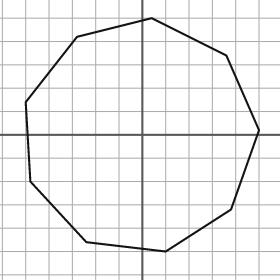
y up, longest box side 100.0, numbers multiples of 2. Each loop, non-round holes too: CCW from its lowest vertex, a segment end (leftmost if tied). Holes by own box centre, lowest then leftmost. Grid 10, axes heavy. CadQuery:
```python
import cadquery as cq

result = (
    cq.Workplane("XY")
    .moveTo(10.0, -50.0)
    .lineTo(38.0, -32.0)
    .lineTo(50.0, 2.0)
    .lineTo(36.0, 34.0)
    .lineTo(4.0, 50.0)
    .lineTo(-28.0, 42.0)
    .lineTo(-50.0, 14.0)
    .lineTo(-48.0, -20.0)
    .lineTo(-24.0, -46.0)
    .close()
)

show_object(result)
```